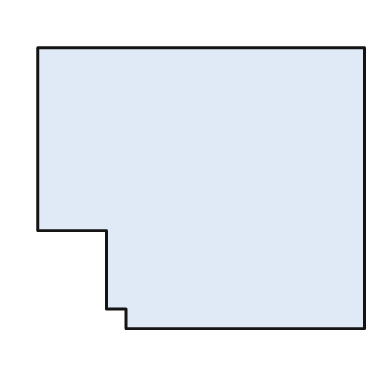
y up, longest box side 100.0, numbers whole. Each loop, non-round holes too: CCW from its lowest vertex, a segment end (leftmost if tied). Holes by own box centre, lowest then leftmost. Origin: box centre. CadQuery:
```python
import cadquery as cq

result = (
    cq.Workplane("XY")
    .moveTo(-23.0, -43.0)
    .lineTo(50.0, -43.0)
    .lineTo(50.0, 43.0)
    .lineTo(-50.0, 43.0)
    .lineTo(-50.0, -13.0)
    .lineTo(-29.0, -13.0)
    .lineTo(-29.0, -37.0)
    .lineTo(-23.0, -37.0)
    .close()
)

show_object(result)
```